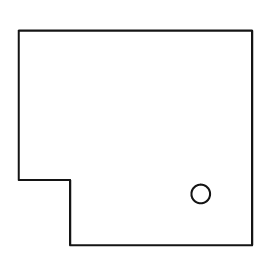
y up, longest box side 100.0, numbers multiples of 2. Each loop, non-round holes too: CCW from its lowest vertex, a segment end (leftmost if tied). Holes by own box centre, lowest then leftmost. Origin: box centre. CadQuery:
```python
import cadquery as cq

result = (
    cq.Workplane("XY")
    .moveTo(-28.0, -46.0)
    .lineTo(50.0, -46.0)
    .lineTo(50.0, 46.0)
    .lineTo(-50.0, 46.0)
    .lineTo(-50.0, -18.0)
    .lineTo(-28.0, -18.0)
    .close()
    .moveTo(28.0, -24.0)
    .circle(4.0)
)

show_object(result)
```